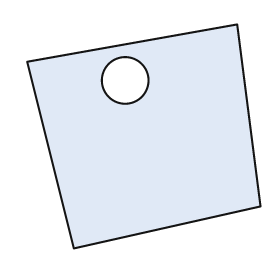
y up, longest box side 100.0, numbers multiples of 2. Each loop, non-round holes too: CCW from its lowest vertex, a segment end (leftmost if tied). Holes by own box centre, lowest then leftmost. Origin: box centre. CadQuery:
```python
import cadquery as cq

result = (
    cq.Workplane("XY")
    .moveTo(-30.0, -48.0)
    .lineTo(50.0, -30.0)
    .lineTo(40.0, 48.0)
    .lineTo(-50.0, 32.0)
    .close()
    .moveTo(-8.0, 24.0)
    .circle(10.0)
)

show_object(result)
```